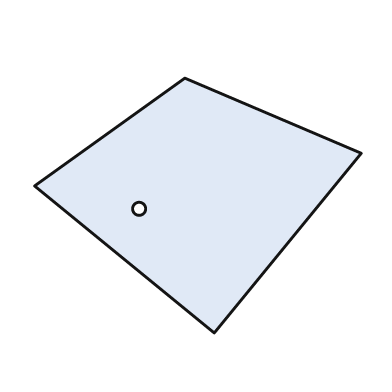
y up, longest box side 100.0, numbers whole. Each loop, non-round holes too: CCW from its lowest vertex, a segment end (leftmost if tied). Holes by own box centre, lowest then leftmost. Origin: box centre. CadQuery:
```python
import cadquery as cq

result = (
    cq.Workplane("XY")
    .moveTo(5.0, -39.0)
    .lineTo(50.0, 16.0)
    .lineTo(-4.0, 39.0)
    .lineTo(-50.0, 6.0)
    .close()
    .moveTo(-18.0, -1.0)
    .circle(2.0)
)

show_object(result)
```